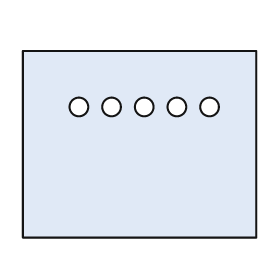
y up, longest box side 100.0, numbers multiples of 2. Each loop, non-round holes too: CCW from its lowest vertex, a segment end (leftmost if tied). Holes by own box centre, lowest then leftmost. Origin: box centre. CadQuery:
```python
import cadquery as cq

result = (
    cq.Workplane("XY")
    .moveTo(-50.0, -40.0)
    .lineTo(50.0, -40.0)
    .lineTo(50.0, 40.0)
    .lineTo(-50.0, 40.0)
    .close()
    .moveTo(-26.0, 16.0)
    .circle(4.0)
    .moveTo(-12.0, 16.0)
    .circle(4.0)
    .moveTo(2.0, 16.0)
    .circle(4.0)
    .moveTo(16.0, 16.0)
    .circle(4.0)
    .moveTo(30.0, 16.0)
    .circle(4.0)
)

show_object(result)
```